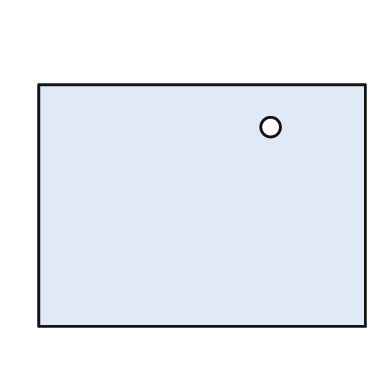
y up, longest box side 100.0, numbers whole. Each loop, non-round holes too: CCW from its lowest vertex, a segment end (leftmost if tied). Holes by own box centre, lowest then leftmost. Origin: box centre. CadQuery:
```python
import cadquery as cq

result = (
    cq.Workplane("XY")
    .moveTo(-50.0, -37.0)
    .lineTo(50.0, -37.0)
    .lineTo(50.0, 37.0)
    .lineTo(-50.0, 37.0)
    .close()
    .moveTo(21.0, 24.0)
    .circle(3.0)
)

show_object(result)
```